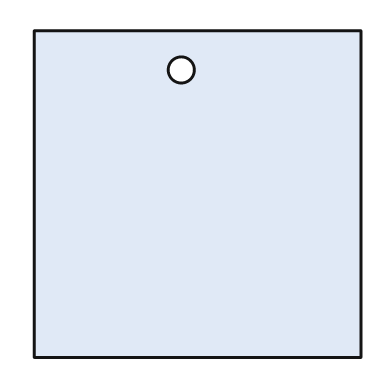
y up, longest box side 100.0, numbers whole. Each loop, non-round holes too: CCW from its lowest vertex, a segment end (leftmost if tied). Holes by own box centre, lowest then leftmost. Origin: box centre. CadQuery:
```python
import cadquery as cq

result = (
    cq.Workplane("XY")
    .moveTo(-50.0, -50.0)
    .lineTo(50.0, -50.0)
    .lineTo(50.0, 50.0)
    .lineTo(-50.0, 50.0)
    .close()
    .moveTo(-5.0, 38.0)
    .circle(4.0)
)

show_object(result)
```